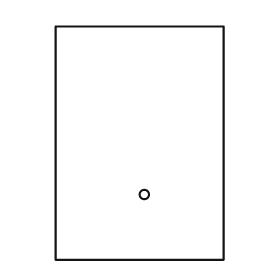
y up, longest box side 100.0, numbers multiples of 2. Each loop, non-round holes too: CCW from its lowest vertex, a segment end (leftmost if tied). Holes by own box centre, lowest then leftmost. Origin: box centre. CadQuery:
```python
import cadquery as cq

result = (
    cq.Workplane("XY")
    .moveTo(-36.0, -50.0)
    .lineTo(36.0, -50.0)
    .lineTo(36.0, 50.0)
    .lineTo(-36.0, 50.0)
    .close()
    .moveTo(2.0, -22.0)
    .circle(2.0)
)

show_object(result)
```